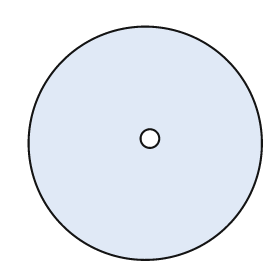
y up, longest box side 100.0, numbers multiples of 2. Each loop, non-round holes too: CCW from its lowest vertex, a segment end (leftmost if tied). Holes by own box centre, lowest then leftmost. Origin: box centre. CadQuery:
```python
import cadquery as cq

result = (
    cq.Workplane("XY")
    .moveTo(0.0, 0.0)
    .circle(50.0)
    .moveTo(2.0, 2.0)
    .circle(4.0)
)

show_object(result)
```